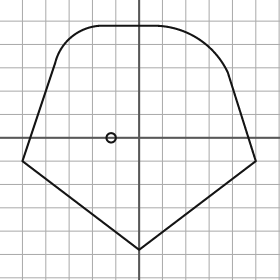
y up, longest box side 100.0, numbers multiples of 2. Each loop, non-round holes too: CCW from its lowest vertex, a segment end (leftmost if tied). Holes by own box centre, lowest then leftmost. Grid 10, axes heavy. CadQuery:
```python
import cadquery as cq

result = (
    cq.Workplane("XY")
    .moveTo(0.0, -48.0)
    .lineTo(50.0, -10.0)
    .lineTo(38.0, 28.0)
    .threePointArc((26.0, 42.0), (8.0, 48.0))
    .lineTo(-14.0, 48.0)
    .threePointArc((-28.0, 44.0), (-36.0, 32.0))
    .lineTo(-50.0, -10.0)
    .close()
    .moveTo(-12.0, 0.0)
    .circle(2.0)
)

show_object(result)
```